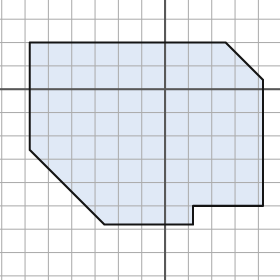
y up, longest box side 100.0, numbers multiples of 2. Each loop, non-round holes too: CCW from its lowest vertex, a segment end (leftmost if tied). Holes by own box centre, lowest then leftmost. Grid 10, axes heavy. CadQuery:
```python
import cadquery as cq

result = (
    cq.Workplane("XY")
    .moveTo(-26.0, -58.0)
    .lineTo(12.0, -58.0)
    .lineTo(12.0, -50.0)
    .lineTo(42.0, -50.0)
    .lineTo(42.0, 4.0)
    .lineTo(26.0, 20.0)
    .lineTo(-58.0, 20.0)
    .lineTo(-58.0, -26.0)
    .close()
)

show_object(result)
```